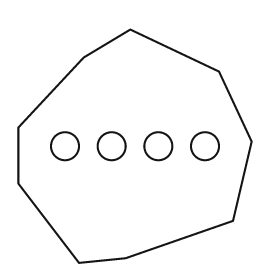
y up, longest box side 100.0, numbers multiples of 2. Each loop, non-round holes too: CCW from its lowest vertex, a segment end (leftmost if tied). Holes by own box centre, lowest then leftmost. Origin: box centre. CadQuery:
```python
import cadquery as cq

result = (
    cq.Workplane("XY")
    .moveTo(-24.0, -50.0)
    .lineTo(-4.0, -48.0)
    .lineTo(42.0, -32.0)
    .lineTo(50.0, 2.0)
    .lineTo(36.0, 32.0)
    .lineTo(-2.0, 50.0)
    .lineTo(-22.0, 38.0)
    .lineTo(-50.0, 8.0)
    .lineTo(-50.0, -16.0)
    .close()
    .moveTo(-30.0, 0.0)
    .circle(6.0)
    .moveTo(-10.0, 0.0)
    .circle(6.0)
    .moveTo(10.0, 0.0)
    .circle(6.0)
    .moveTo(30.0, 0.0)
    .circle(6.0)
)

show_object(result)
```